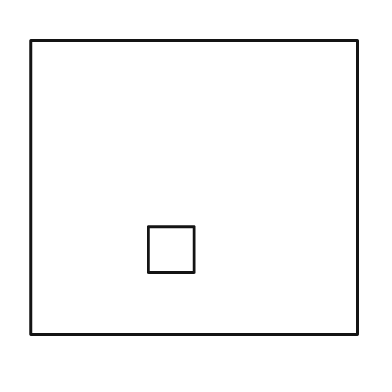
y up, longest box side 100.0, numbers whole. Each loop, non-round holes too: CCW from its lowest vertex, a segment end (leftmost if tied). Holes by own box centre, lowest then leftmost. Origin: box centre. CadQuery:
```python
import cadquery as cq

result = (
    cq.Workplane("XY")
    .moveTo(-50.0, -45.0)
    .lineTo(50.0, -45.0)
    .lineTo(50.0, 45.0)
    .lineTo(-50.0, 45.0)
    .close()
    .moveTo(-14.0, -26.0)
    .lineTo(0.0, -26.0)
    .lineTo(0.0, -12.0)
    .lineTo(-14.0, -12.0)
    .close()
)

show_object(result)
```